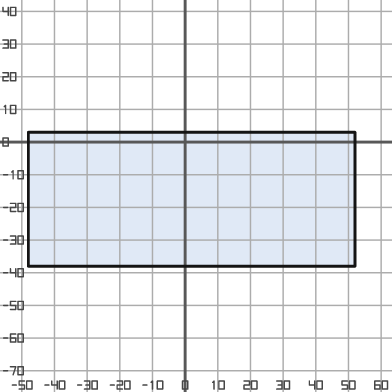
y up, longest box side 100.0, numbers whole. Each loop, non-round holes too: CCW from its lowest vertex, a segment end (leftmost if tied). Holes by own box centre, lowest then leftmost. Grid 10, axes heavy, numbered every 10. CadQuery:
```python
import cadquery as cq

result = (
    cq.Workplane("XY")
    .moveTo(-48.0, -38.0)
    .lineTo(52.0, -38.0)
    .lineTo(52.0, 3.0)
    .lineTo(-48.0, 3.0)
    .close()
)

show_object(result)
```